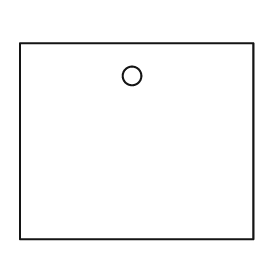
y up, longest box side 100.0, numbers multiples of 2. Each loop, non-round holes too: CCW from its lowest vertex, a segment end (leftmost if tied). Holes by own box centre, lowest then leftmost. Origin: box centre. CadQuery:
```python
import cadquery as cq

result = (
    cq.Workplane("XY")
    .moveTo(-50.0, -42.0)
    .lineTo(50.0, -42.0)
    .lineTo(50.0, 42.0)
    .lineTo(-50.0, 42.0)
    .close()
    .moveTo(-2.0, 28.0)
    .circle(4.0)
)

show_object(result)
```